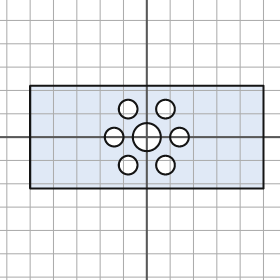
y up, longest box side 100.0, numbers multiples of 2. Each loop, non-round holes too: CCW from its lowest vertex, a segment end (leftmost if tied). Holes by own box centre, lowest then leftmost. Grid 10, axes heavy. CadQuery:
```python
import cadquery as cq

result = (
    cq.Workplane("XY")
    .moveTo(-50.0, -22.0)
    .lineTo(50.0, -22.0)
    .lineTo(50.0, 22.0)
    .lineTo(-50.0, 22.0)
    .close()
    .moveTo(-8.0, -12.0)
    .circle(4.0)
    .moveTo(8.0, -12.0)
    .circle(4.0)
    .moveTo(-14.0, 0.0)
    .circle(4.0)
    .moveTo(0.0, 0.0)
    .circle(6.0)
    .moveTo(14.0, 0.0)
    .circle(4.0)
    .moveTo(-8.0, 12.0)
    .circle(4.0)
    .moveTo(8.0, 12.0)
    .circle(4.0)
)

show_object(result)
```